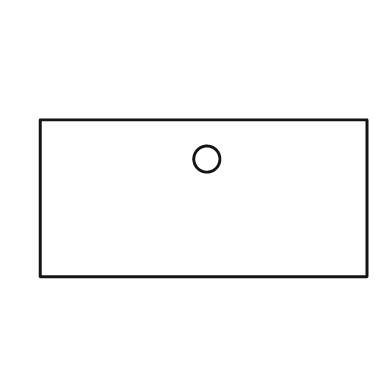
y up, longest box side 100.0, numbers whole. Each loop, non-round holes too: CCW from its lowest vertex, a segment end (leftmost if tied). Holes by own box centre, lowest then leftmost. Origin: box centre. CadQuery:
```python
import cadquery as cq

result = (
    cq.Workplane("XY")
    .moveTo(-50.0, -24.0)
    .lineTo(50.0, -24.0)
    .lineTo(50.0, 24.0)
    .lineTo(-50.0, 24.0)
    .close()
    .moveTo(1.0, 12.0)
    .circle(4.0)
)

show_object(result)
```